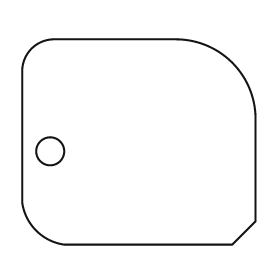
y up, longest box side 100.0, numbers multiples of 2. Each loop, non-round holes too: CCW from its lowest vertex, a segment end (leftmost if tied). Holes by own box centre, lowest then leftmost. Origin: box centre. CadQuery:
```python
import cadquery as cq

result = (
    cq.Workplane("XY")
    .moveTo(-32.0, -44.0)
    .lineTo(40.0, -44.0)
    .lineTo(50.0, -34.0)
    .lineTo(50.0, 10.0)
    .threePointArc((40.0, 34.0), (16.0, 44.0))
    .lineTo(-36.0, 44.0)
    .threePointArc((-46.0, 40.0), (-50.0, 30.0))
    .lineTo(-50.0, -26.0)
    .threePointArc((-44.0, -38.0), (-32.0, -44.0))
    .close()
    .moveTo(-38.0, -4.0)
    .circle(6.0)
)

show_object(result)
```